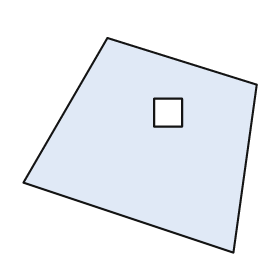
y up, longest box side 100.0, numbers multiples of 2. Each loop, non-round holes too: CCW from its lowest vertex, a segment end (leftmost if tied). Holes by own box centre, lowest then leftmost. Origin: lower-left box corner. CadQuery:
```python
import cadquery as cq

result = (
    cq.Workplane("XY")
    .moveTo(90.0, 0.0)
    .lineTo(100.0, 72.0)
    .lineTo(36.0, 92.0)
    .lineTo(0.0, 30.0)
    .close()
    .moveTo(56.0, 54.0)
    .lineTo(68.0, 54.0)
    .lineTo(68.0, 66.0)
    .lineTo(56.0, 66.0)
    .close()
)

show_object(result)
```